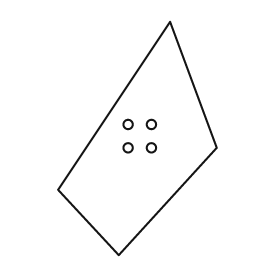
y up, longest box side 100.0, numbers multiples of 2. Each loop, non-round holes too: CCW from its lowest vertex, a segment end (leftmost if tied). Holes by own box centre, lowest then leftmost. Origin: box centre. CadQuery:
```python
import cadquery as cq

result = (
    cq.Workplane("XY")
    .moveTo(-8.0, -50.0)
    .lineTo(34.0, -4.0)
    .lineTo(14.0, 50.0)
    .lineTo(-34.0, -22.0)
    .close()
    .moveTo(-4.0, -4.0)
    .circle(2.0)
    .moveTo(6.0, -4.0)
    .circle(2.0)
    .moveTo(-4.0, 6.0)
    .circle(2.0)
    .moveTo(6.0, 6.0)
    .circle(2.0)
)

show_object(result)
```